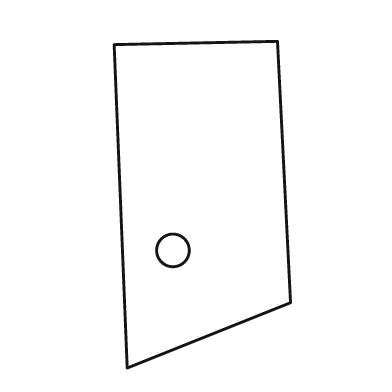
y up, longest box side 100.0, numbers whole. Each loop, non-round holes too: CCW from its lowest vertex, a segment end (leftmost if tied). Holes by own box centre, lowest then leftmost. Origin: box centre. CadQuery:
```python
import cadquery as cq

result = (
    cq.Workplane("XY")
    .moveTo(-23.0, -50.0)
    .lineTo(27.0, -30.0)
    .lineTo(23.0, 50.0)
    .lineTo(-27.0, 49.0)
    .close()
    .moveTo(-9.0, -14.0)
    .circle(5.0)
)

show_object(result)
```